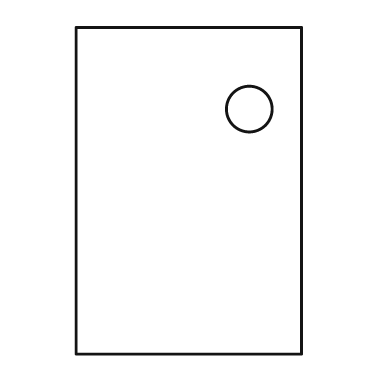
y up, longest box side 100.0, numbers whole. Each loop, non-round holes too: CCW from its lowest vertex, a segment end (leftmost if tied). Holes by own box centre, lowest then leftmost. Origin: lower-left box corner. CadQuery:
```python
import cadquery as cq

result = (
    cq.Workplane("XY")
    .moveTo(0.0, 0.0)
    .lineTo(69.0, 0.0)
    .lineTo(69.0, 100.0)
    .lineTo(0.0, 100.0)
    .close()
    .moveTo(53.0, 75.0)
    .circle(7.0)
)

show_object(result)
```